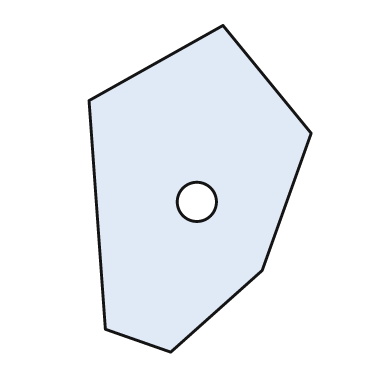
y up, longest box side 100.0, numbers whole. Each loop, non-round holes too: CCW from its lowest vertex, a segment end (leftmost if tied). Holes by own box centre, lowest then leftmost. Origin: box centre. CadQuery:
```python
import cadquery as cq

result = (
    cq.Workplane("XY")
    .moveTo(-9.0, -50.0)
    .lineTo(19.0, -25.0)
    .lineTo(34.0, 17.0)
    .lineTo(7.0, 50.0)
    .lineTo(-34.0, 27.0)
    .lineTo(-29.0, -43.0)
    .close()
    .moveTo(-1.0, -4.0)
    .circle(6.0)
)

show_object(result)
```